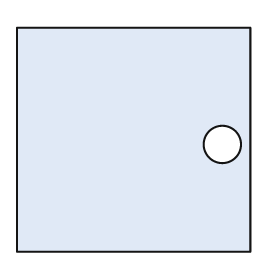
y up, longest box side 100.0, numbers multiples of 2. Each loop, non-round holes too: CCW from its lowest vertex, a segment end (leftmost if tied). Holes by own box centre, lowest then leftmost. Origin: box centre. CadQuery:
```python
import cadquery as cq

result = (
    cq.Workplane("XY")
    .moveTo(-50.0, -48.0)
    .lineTo(50.0, -48.0)
    .lineTo(50.0, 48.0)
    .lineTo(-50.0, 48.0)
    .close()
    .moveTo(38.0, -2.0)
    .circle(8.0)
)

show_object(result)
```